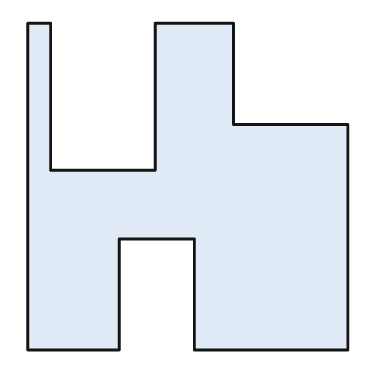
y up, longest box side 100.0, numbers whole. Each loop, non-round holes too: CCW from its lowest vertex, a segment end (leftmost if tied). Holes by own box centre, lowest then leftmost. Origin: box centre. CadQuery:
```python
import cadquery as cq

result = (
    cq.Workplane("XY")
    .moveTo(-49.0, -50.0)
    .lineTo(-21.0, -50.0)
    .lineTo(-21.0, -16.0)
    .lineTo(2.0, -16.0)
    .lineTo(2.0, -50.0)
    .lineTo(49.0, -50.0)
    .lineTo(49.0, 19.0)
    .lineTo(14.0, 19.0)
    .lineTo(14.0, 50.0)
    .lineTo(-10.0, 50.0)
    .lineTo(-10.0, 5.0)
    .lineTo(-42.0, 5.0)
    .lineTo(-42.0, 50.0)
    .lineTo(-49.0, 50.0)
    .close()
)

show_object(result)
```